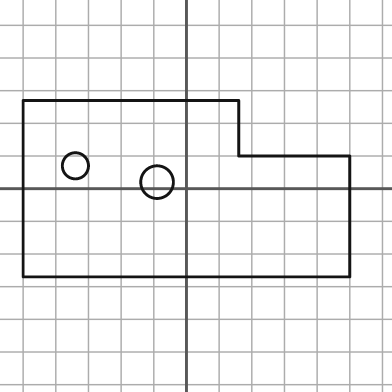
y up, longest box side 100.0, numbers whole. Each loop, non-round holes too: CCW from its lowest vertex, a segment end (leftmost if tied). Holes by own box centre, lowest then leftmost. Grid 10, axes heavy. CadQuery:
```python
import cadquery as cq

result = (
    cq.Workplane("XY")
    .moveTo(-50.0, -27.0)
    .lineTo(50.0, -27.0)
    .lineTo(50.0, 10.0)
    .lineTo(16.0, 10.0)
    .lineTo(16.0, 27.0)
    .lineTo(-50.0, 27.0)
    .close()
    .moveTo(-9.0, 2.0)
    .circle(5.0)
    .moveTo(-34.0, 7.0)
    .circle(4.0)
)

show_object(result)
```